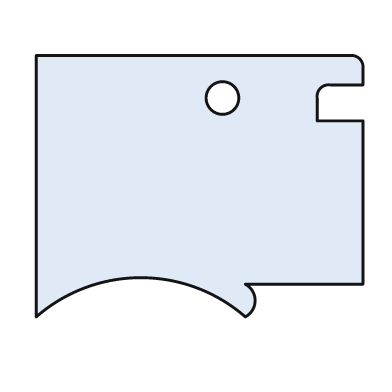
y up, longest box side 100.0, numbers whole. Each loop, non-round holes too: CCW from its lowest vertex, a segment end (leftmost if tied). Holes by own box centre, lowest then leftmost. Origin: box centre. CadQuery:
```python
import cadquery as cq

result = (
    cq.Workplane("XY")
    .moveTo(-50.0, -40.0)
    .threePointArc((-18.0, -28.0), (14.0, -40.0))
    .threePointArc((17.0, -35.0), (14.0, -30.0))
    .lineTo(50.0, -30.0)
    .lineTo(50.0, 20.0)
    .lineTo(36.0, 20.0)
    .lineTo(36.0, 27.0)
    .threePointArc((37.0, 30.0), (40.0, 31.0))
    .lineTo(50.0, 31.0)
    .lineTo(50.0, 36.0)
    .threePointArc((49.0, 39.0), (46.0, 40.0))
    .lineTo(-50.0, 40.0)
    .close()
    .moveTo(7.0, 27.0)
    .circle(5.0)
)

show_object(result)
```